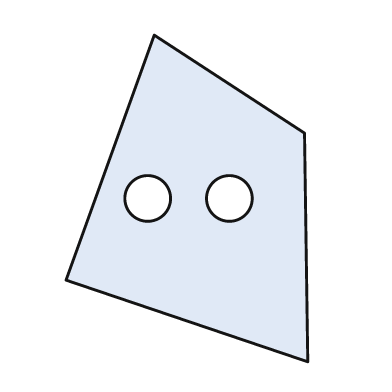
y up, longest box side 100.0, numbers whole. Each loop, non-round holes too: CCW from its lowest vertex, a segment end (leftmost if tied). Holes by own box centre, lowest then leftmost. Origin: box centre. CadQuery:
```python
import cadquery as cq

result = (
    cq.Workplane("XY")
    .moveTo(37.0, -50.0)
    .lineTo(36.0, 20.0)
    .lineTo(-10.0, 50.0)
    .lineTo(-37.0, -25.0)
    .close()
    .moveTo(-12.0, 0.0)
    .circle(7.0)
    .moveTo(13.0, 0.0)
    .circle(7.0)
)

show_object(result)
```